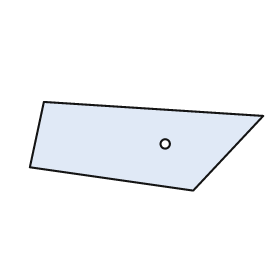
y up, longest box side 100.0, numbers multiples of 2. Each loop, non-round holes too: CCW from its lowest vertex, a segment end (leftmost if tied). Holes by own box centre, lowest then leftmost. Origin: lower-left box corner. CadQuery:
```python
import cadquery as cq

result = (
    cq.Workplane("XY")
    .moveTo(70.0, 0.0)
    .lineTo(100.0, 32.0)
    .lineTo(6.0, 38.0)
    .lineTo(0.0, 10.0)
    .close()
    .moveTo(58.0, 20.0)
    .circle(2.0)
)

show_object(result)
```